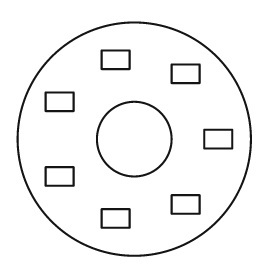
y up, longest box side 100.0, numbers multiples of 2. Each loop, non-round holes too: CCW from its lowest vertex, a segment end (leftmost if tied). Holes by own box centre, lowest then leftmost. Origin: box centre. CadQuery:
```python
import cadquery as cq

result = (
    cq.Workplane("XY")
    .moveTo(0.0, 0.0)
    .circle(50.0)
    .moveTo(-14.0, -38.0)
    .lineTo(-2.0, -38.0)
    .lineTo(-2.0, -30.0)
    .lineTo(-14.0, -30.0)
    .close()
    .moveTo(16.0, -32.0)
    .lineTo(28.0, -32.0)
    .lineTo(28.0, -24.0)
    .lineTo(16.0, -24.0)
    .close()
    .moveTo(-38.0, -20.0)
    .lineTo(-26.0, -20.0)
    .lineTo(-26.0, -12.0)
    .lineTo(-38.0, -12.0)
    .close()
    .moveTo(0.0, 0.0)
    .circle(16.0)
    .moveTo(30.0, -4.0)
    .lineTo(42.0, -4.0)
    .lineTo(42.0, 4.0)
    .lineTo(30.0, 4.0)
    .close()
    .moveTo(-38.0, 12.0)
    .lineTo(-26.0, 12.0)
    .lineTo(-26.0, 20.0)
    .lineTo(-38.0, 20.0)
    .close()
    .moveTo(16.0, 24.0)
    .lineTo(28.0, 24.0)
    .lineTo(28.0, 32.0)
    .lineTo(16.0, 32.0)
    .close()
    .moveTo(-14.0, 30.0)
    .lineTo(-2.0, 30.0)
    .lineTo(-2.0, 38.0)
    .lineTo(-14.0, 38.0)
    .close()
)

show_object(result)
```